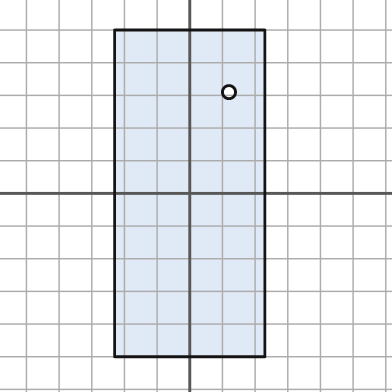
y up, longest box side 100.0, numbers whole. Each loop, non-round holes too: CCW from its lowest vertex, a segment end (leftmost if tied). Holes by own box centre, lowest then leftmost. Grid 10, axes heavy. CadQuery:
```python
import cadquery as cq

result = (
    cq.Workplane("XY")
    .moveTo(-23.0, -50.0)
    .lineTo(23.0, -50.0)
    .lineTo(23.0, 50.0)
    .lineTo(-23.0, 50.0)
    .close()
    .moveTo(12.0, 31.0)
    .circle(2.0)
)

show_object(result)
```